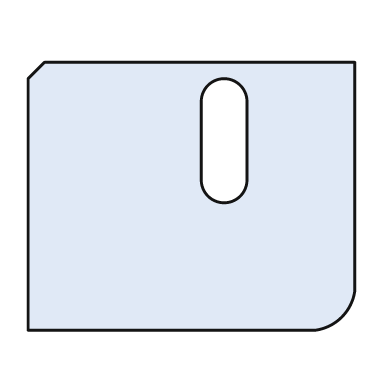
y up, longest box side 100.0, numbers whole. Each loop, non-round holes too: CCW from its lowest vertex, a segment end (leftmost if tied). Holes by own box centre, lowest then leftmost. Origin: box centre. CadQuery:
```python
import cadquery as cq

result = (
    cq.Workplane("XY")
    .moveTo(-50.0, -41.0)
    .lineTo(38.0, -41.0)
    .threePointArc((46.0, -37.0), (50.0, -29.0))
    .lineTo(50.0, 41.0)
    .lineTo(-45.0, 41.0)
    .lineTo(-50.0, 36.0)
    .close()
    .moveTo(3.0, 5.0)
    .threePointArc((10.0, -2.0), (17.0, 5.0))
    .lineTo(17.0, 29.0)
    .threePointArc((10.0, 36.0), (3.0, 29.0))
    .close()
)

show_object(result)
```